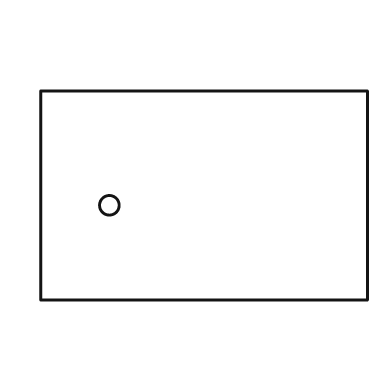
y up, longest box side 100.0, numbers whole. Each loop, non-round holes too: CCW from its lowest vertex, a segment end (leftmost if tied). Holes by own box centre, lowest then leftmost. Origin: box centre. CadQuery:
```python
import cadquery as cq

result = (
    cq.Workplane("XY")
    .moveTo(-50.0, -32.0)
    .lineTo(50.0, -32.0)
    .lineTo(50.0, 32.0)
    .lineTo(-50.0, 32.0)
    .close()
    .moveTo(-29.0, -3.0)
    .circle(3.0)
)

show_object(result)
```